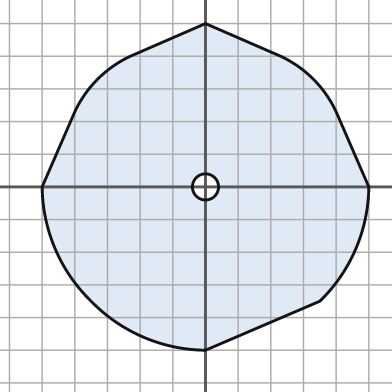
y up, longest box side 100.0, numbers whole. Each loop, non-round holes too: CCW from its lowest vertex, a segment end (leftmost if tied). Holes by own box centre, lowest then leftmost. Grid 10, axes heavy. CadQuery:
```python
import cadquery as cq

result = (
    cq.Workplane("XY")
    .moveTo(0.0, -50.0)
    .lineTo(35.0, -35.0)
    .threePointArc((46.0, -19.0), (50.0, 0.0))
    .lineTo(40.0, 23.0)
    .threePointArc((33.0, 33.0), (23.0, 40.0))
    .lineTo(0.0, 50.0)
    .lineTo(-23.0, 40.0)
    .threePointArc((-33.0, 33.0), (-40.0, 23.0))
    .lineTo(-50.0, 0.0)
    .threePointArc((-46.0, -19.0), (-35.0, -35.0))
    .threePointArc((-19.0, -46.0), (0.0, -50.0))
    .close()
    .moveTo(0.0, 0.0)
    .circle(4.0)
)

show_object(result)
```